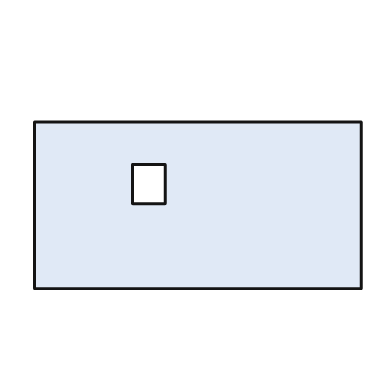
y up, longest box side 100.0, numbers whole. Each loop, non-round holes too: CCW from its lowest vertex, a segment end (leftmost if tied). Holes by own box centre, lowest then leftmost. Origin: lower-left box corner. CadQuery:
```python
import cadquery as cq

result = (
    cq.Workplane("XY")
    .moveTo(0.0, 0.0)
    .lineTo(100.0, 0.0)
    .lineTo(100.0, 51.0)
    .lineTo(0.0, 51.0)
    .close()
    .moveTo(30.0, 26.0)
    .lineTo(40.0, 26.0)
    .lineTo(40.0, 38.0)
    .lineTo(30.0, 38.0)
    .close()
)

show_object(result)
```